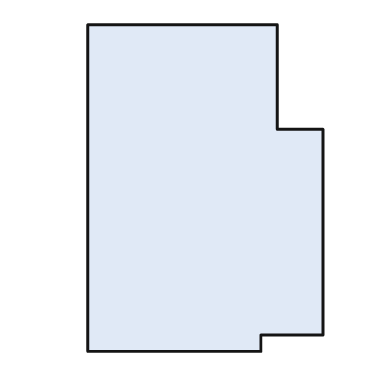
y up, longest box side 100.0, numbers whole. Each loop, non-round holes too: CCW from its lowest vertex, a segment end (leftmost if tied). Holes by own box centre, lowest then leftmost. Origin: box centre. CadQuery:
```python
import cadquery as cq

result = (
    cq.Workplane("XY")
    .moveTo(-36.0, -50.0)
    .lineTo(17.0, -50.0)
    .lineTo(17.0, -45.0)
    .lineTo(36.0, -45.0)
    .lineTo(36.0, 18.0)
    .lineTo(22.0, 18.0)
    .lineTo(22.0, 50.0)
    .lineTo(-36.0, 50.0)
    .close()
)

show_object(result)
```